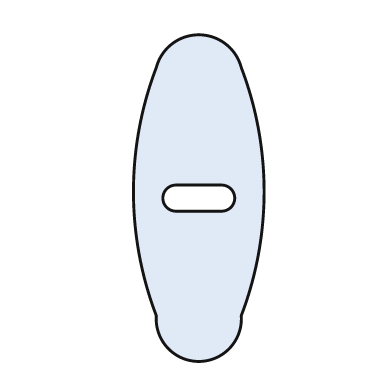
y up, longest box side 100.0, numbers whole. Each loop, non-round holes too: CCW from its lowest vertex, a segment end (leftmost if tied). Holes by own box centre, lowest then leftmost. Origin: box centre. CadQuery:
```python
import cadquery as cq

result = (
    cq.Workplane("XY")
    .moveTo(-13.0, -36.0)
    .threePointArc((0.0, -50.0), (13.0, -36.0))
    .threePointArc((20.0, 2.0), (13.0, 40.0))
    .threePointArc((0.0, 50.0), (-13.0, 40.0))
    .threePointArc((-20.0, 2.0), (-13.0, -36.0))
    .close()
    .moveTo(-7.0, -4.0)
    .lineTo(7.0, -4.0)
    .threePointArc((11.0, 0.0), (7.0, 4.0))
    .lineTo(-7.0, 4.0)
    .threePointArc((-11.0, 0.0), (-7.0, -4.0))
    .close()
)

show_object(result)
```